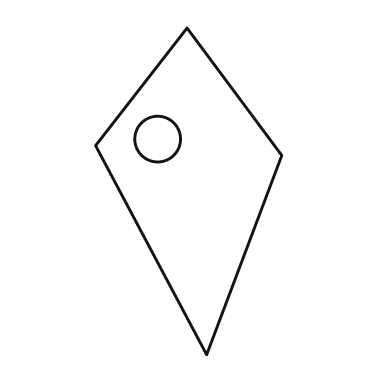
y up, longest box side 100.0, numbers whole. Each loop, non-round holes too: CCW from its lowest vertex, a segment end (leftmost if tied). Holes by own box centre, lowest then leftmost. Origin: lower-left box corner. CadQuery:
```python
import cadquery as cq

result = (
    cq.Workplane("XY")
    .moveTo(34.0, 0.0)
    .lineTo(57.0, 61.0)
    .lineTo(28.0, 100.0)
    .lineTo(0.0, 64.0)
    .close()
    .moveTo(19.0, 66.0)
    .circle(7.0)
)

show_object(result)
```